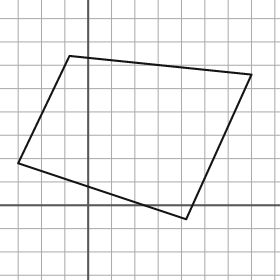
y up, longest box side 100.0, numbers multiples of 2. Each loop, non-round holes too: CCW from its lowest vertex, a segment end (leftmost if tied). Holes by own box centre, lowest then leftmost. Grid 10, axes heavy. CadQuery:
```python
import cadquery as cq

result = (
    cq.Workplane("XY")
    .moveTo(42.0, -6.0)
    .lineTo(70.0, 56.0)
    .lineTo(-8.0, 64.0)
    .lineTo(-30.0, 18.0)
    .close()
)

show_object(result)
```